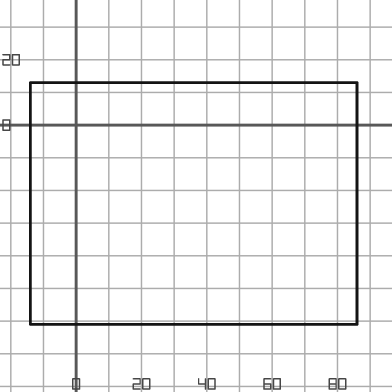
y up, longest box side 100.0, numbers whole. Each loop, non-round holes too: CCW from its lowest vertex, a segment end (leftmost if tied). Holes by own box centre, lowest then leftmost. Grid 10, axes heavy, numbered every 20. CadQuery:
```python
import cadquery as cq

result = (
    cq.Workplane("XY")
    .moveTo(-14.0, -61.0)
    .lineTo(86.0, -61.0)
    .lineTo(86.0, 13.0)
    .lineTo(-14.0, 13.0)
    .close()
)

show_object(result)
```